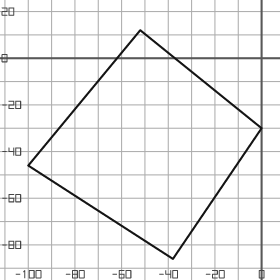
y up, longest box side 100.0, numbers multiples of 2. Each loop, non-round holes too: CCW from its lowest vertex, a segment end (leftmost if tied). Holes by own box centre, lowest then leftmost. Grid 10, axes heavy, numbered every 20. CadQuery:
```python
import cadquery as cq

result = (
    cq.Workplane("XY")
    .moveTo(-38.0, -86.0)
    .lineTo(0.0, -30.0)
    .lineTo(-52.0, 12.0)
    .lineTo(-100.0, -46.0)
    .close()
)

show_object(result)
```